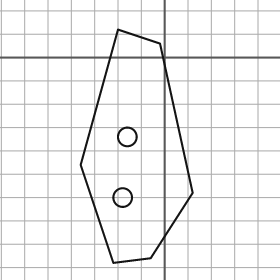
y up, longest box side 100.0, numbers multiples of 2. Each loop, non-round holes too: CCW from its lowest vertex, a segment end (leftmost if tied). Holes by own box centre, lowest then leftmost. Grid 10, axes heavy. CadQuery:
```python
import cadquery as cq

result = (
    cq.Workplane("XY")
    .moveTo(-22.0, -88.0)
    .lineTo(-6.0, -86.0)
    .lineTo(12.0, -58.0)
    .lineTo(-2.0, 6.0)
    .lineTo(-20.0, 12.0)
    .lineTo(-36.0, -46.0)
    .close()
    .moveTo(-18.0, -60.0)
    .circle(4.0)
    .moveTo(-16.0, -34.0)
    .circle(4.0)
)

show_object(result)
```